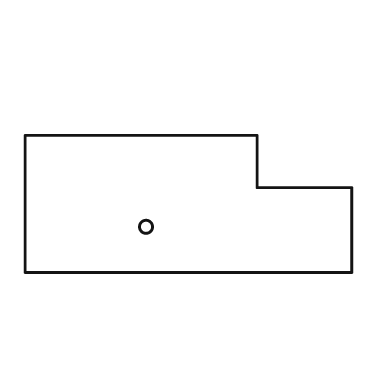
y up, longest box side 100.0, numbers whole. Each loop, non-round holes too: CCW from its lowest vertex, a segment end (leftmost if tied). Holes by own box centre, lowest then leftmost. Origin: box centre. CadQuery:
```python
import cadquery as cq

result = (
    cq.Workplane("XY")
    .moveTo(-50.0, -21.0)
    .lineTo(50.0, -21.0)
    .lineTo(50.0, 5.0)
    .lineTo(21.0, 5.0)
    .lineTo(21.0, 21.0)
    .lineTo(-50.0, 21.0)
    .close()
    .moveTo(-13.0, -7.0)
    .circle(2.0)
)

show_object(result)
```